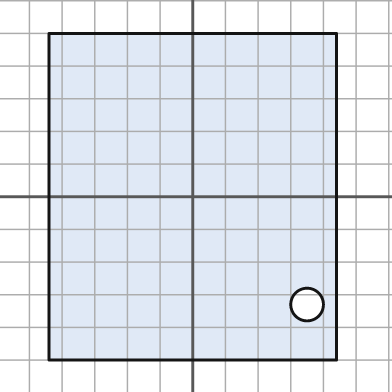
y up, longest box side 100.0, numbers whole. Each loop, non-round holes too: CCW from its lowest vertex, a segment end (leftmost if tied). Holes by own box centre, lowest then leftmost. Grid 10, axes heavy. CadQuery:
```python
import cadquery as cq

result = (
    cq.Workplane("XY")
    .moveTo(-44.0, -50.0)
    .lineTo(44.0, -50.0)
    .lineTo(44.0, 50.0)
    .lineTo(-44.0, 50.0)
    .close()
    .moveTo(35.0, -33.0)
    .circle(5.0)
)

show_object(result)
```